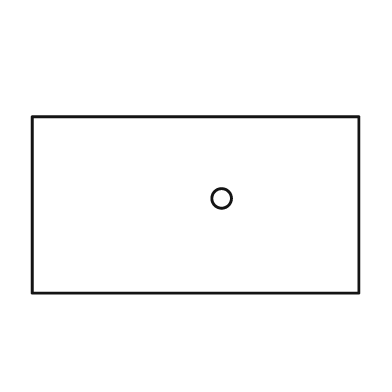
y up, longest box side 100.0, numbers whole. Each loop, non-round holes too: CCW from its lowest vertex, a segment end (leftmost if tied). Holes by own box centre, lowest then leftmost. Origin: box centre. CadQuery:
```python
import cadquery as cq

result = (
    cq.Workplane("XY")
    .moveTo(-50.0, -27.0)
    .lineTo(50.0, -27.0)
    .lineTo(50.0, 27.0)
    .lineTo(-50.0, 27.0)
    .close()
    .moveTo(8.0, 2.0)
    .circle(3.0)
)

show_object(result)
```